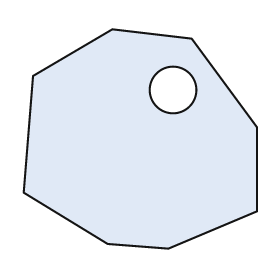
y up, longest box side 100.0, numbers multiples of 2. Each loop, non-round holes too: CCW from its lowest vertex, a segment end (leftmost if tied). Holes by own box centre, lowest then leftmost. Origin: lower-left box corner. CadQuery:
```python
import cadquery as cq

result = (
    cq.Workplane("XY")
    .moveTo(62.0, 0.0)
    .lineTo(100.0, 16.0)
    .lineTo(100.0, 52.0)
    .lineTo(72.0, 90.0)
    .lineTo(38.0, 94.0)
    .lineTo(4.0, 74.0)
    .lineTo(0.0, 24.0)
    .lineTo(36.0, 2.0)
    .close()
    .moveTo(64.0, 68.0)
    .circle(10.0)
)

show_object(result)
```